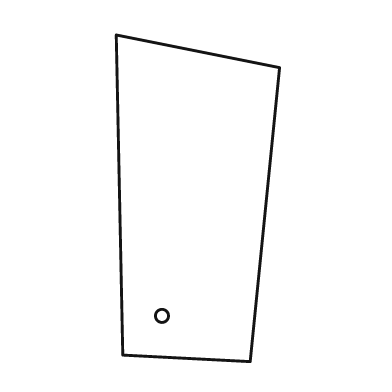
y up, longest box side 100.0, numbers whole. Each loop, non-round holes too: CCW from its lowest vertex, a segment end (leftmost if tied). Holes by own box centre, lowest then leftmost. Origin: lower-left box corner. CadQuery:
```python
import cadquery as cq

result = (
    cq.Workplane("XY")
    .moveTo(41.0, 0.0)
    .lineTo(50.0, 90.0)
    .lineTo(0.0, 100.0)
    .lineTo(2.0, 2.0)
    .close()
    .moveTo(14.0, 14.0)
    .circle(2.0)
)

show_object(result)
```